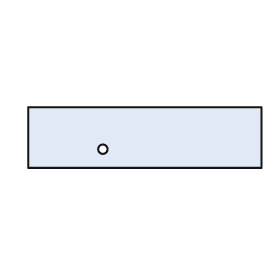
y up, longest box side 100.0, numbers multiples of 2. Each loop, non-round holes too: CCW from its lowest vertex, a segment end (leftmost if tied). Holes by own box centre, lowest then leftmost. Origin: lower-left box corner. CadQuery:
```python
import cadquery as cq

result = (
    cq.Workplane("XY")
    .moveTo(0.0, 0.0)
    .lineTo(100.0, 0.0)
    .lineTo(100.0, 26.0)
    .lineTo(0.0, 26.0)
    .close()
    .moveTo(32.0, 8.0)
    .circle(2.0)
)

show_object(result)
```